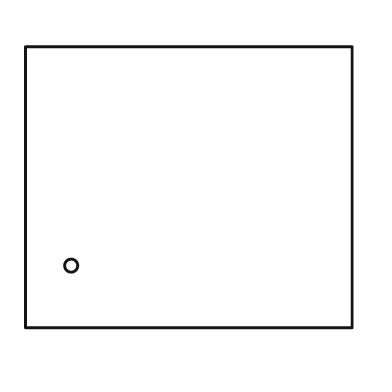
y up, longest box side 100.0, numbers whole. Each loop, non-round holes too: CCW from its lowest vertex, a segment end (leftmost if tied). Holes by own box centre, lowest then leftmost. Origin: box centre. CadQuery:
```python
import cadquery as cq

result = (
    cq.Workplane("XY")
    .moveTo(-50.0, -43.0)
    .lineTo(50.0, -43.0)
    .lineTo(50.0, 43.0)
    .lineTo(-50.0, 43.0)
    .close()
    .moveTo(-36.0, -24.0)
    .circle(2.0)
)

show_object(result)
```